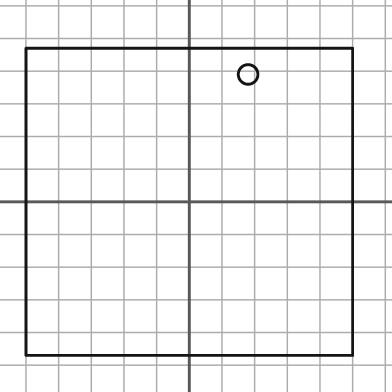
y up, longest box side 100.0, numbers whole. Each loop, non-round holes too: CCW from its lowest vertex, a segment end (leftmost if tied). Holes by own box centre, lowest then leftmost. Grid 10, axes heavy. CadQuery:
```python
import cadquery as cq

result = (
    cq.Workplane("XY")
    .moveTo(-50.0, -47.0)
    .lineTo(50.0, -47.0)
    .lineTo(50.0, 47.0)
    .lineTo(-50.0, 47.0)
    .close()
    .moveTo(18.0, 39.0)
    .circle(3.0)
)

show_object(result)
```